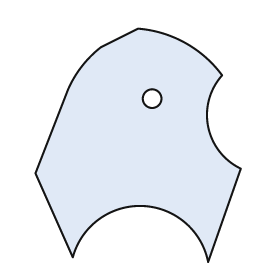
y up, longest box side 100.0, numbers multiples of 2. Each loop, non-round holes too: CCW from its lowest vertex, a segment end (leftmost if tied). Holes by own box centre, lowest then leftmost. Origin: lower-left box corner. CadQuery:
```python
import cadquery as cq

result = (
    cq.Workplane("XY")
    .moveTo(74.0, 0.0)
    .lineTo(88.0, 40.0)
    .threePointArc((74.0, 58.0), (80.0, 80.0))
    .threePointArc((64.0, 94.0), (44.0, 100.0))
    .lineTo(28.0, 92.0)
    .threePointArc((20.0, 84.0), (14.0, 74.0))
    .lineTo(0.0, 38.0)
    .lineTo(16.0, 2.0)
    .threePointArc((46.0, 24.0), (74.0, 0.0))
    .close()
    .moveTo(50.0, 70.0)
    .circle(4.0)
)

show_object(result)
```